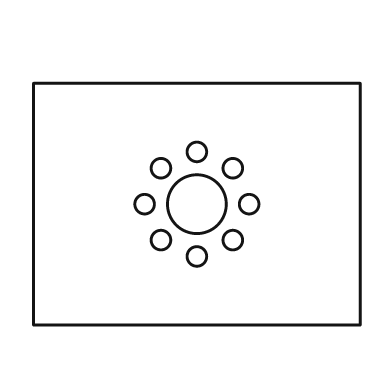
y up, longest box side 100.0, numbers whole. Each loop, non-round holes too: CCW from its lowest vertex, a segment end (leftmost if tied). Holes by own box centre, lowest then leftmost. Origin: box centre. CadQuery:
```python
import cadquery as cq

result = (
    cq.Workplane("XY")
    .moveTo(-50.0, -37.0)
    .lineTo(50.0, -37.0)
    .lineTo(50.0, 37.0)
    .lineTo(-50.0, 37.0)
    .close()
    .moveTo(0.0, -16.0)
    .circle(3.0)
    .moveTo(-11.0, -11.0)
    .circle(3.0)
    .moveTo(11.0, -11.0)
    .circle(3.0)
    .moveTo(-16.0, 0.0)
    .circle(3.0)
    .moveTo(0.0, 0.0)
    .circle(9.0)
    .moveTo(16.0, 0.0)
    .circle(3.0)
    .moveTo(-11.0, 11.0)
    .circle(3.0)
    .moveTo(11.0, 11.0)
    .circle(3.0)
    .moveTo(0.0, 16.0)
    .circle(3.0)
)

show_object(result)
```